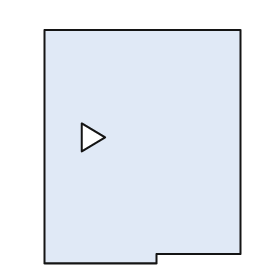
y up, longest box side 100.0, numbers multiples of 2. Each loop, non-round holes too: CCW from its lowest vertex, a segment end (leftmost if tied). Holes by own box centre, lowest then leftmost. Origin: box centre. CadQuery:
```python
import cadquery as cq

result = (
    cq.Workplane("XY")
    .moveTo(-42.0, -50.0)
    .lineTo(6.0, -50.0)
    .lineTo(6.0, -46.0)
    .lineTo(42.0, -46.0)
    .lineTo(42.0, 50.0)
    .lineTo(-42.0, 50.0)
    .close()
    .moveTo(-26.0, -2.0)
    .lineTo(-16.0, 4.0)
    .lineTo(-26.0, 10.0)
    .close()
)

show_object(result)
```